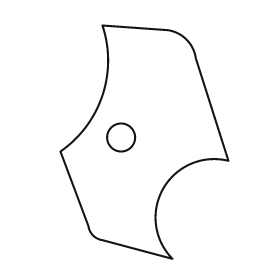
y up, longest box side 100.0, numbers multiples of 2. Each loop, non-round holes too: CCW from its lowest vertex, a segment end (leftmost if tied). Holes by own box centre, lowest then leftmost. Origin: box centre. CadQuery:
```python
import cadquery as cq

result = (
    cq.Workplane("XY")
    .moveTo(12.0, -50.0)
    .threePointArc((8.0, -20.0), (36.0, -8.0))
    .lineTo(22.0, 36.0)
    .threePointArc((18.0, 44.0), (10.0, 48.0))
    .lineTo(-18.0, 50.0)
    .threePointArc((-18.0, 20.0), (-36.0, -4.0))
    .lineTo(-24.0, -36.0)
    .threePointArc((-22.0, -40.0), (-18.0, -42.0))
    .close()
    .moveTo(-10.0, 2.0)
    .circle(6.0)
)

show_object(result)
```